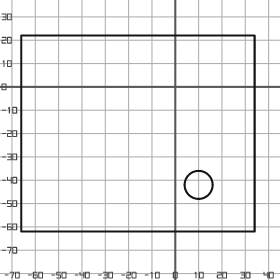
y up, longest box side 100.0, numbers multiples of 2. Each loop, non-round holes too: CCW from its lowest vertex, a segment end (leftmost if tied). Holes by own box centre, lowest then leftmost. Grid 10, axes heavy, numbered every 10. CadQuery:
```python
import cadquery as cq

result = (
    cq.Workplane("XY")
    .moveTo(-66.0, -62.0)
    .lineTo(34.0, -62.0)
    .lineTo(34.0, 22.0)
    .lineTo(-66.0, 22.0)
    .close()
    .moveTo(10.0, -42.0)
    .circle(6.0)
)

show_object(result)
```